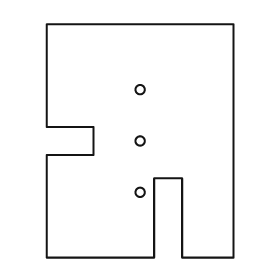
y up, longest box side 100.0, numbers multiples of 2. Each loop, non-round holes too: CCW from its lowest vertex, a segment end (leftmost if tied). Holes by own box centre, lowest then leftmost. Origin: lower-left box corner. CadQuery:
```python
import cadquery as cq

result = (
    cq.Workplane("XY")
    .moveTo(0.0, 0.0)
    .lineTo(46.0, 0.0)
    .lineTo(46.0, 34.0)
    .lineTo(58.0, 34.0)
    .lineTo(58.0, 0.0)
    .lineTo(80.0, 0.0)
    .lineTo(80.0, 100.0)
    .lineTo(0.0, 100.0)
    .lineTo(0.0, 56.0)
    .lineTo(20.0, 56.0)
    .lineTo(20.0, 44.0)
    .lineTo(0.0, 44.0)
    .close()
    .moveTo(40.0, 28.0)
    .circle(2.0)
    .moveTo(40.0, 50.0)
    .circle(2.0)
    .moveTo(40.0, 72.0)
    .circle(2.0)
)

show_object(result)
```